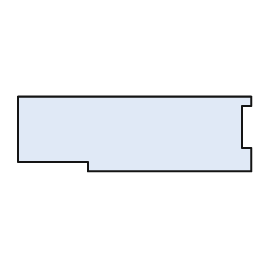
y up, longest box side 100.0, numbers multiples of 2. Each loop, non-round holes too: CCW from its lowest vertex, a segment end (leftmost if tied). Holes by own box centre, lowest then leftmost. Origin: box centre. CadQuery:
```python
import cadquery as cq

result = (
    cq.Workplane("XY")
    .moveTo(-20.0, -16.0)
    .lineTo(50.0, -16.0)
    .lineTo(50.0, -6.0)
    .lineTo(46.0, -6.0)
    .lineTo(46.0, 12.0)
    .lineTo(50.0, 12.0)
    .lineTo(50.0, 16.0)
    .lineTo(-50.0, 16.0)
    .lineTo(-50.0, -12.0)
    .lineTo(-20.0, -12.0)
    .close()
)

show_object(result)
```